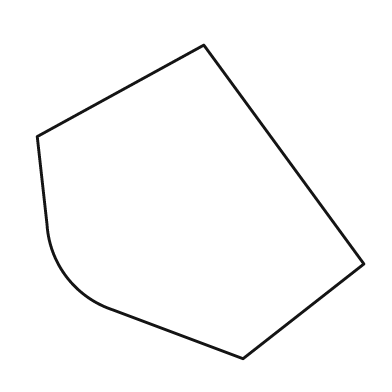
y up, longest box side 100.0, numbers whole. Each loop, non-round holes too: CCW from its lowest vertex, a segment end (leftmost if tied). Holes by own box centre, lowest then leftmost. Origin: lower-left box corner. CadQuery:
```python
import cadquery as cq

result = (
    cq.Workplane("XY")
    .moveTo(63.0, 0.0)
    .lineTo(100.0, 29.0)
    .lineTo(51.0, 96.0)
    .lineTo(0.0, 68.0)
    .lineTo(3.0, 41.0)
    .threePointArc((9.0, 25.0), (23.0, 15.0))
    .close()
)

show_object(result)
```